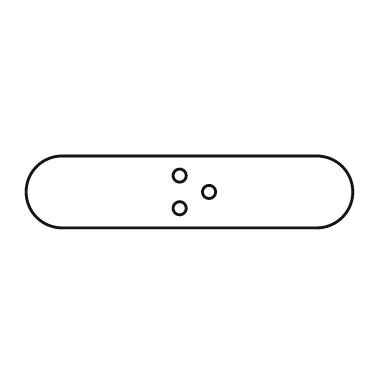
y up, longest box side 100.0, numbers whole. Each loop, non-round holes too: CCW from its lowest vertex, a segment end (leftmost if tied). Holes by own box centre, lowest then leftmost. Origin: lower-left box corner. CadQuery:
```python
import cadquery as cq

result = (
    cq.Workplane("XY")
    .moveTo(11.0, 0.0)
    .lineTo(89.0, 0.0)
    .threePointArc((100.0, 11.0), (89.0, 22.0))
    .lineTo(11.0, 22.0)
    .threePointArc((0.0, 11.0), (11.0, 0.0))
    .close()
    .moveTo(47.0, 6.0)
    .circle(2.0)
    .moveTo(56.0, 11.0)
    .circle(2.0)
    .moveTo(47.0, 16.0)
    .circle(2.0)
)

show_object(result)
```